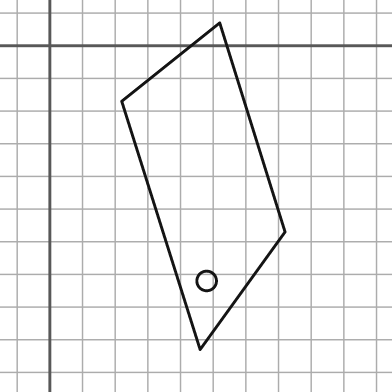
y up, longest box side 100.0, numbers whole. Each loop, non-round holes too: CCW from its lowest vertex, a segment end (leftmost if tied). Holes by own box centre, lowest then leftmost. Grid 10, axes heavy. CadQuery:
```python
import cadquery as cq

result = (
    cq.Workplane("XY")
    .moveTo(46.0, -93.0)
    .lineTo(72.0, -57.0)
    .lineTo(52.0, 7.0)
    .lineTo(22.0, -17.0)
    .close()
    .moveTo(48.0, -72.0)
    .circle(3.0)
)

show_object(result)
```